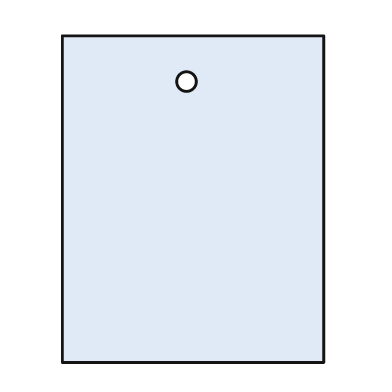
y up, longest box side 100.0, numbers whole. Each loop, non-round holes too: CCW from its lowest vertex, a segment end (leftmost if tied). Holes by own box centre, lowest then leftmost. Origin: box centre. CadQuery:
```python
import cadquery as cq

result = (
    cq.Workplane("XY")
    .moveTo(-40.0, -50.0)
    .lineTo(40.0, -50.0)
    .lineTo(40.0, 50.0)
    .lineTo(-40.0, 50.0)
    .close()
    .moveTo(-2.0, 36.0)
    .circle(3.0)
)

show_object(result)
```